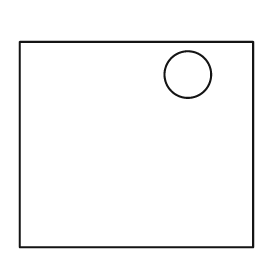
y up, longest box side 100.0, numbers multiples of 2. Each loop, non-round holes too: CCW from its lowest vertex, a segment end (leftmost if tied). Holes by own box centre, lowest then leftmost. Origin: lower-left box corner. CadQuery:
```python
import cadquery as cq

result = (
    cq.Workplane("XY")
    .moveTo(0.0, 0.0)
    .lineTo(100.0, 0.0)
    .lineTo(100.0, 88.0)
    .lineTo(0.0, 88.0)
    .close()
    .moveTo(72.0, 74.0)
    .circle(10.0)
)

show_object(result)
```